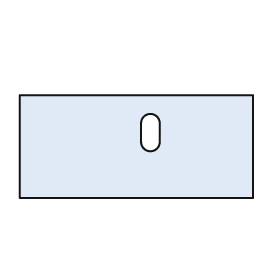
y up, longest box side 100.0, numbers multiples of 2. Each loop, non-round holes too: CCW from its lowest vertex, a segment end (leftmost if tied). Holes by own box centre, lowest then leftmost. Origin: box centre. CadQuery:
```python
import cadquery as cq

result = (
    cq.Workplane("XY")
    .moveTo(-50.0, -22.0)
    .lineTo(50.0, -22.0)
    .lineTo(50.0, 22.0)
    .lineTo(-50.0, 22.0)
    .close()
    .moveTo(2.0, 2.0)
    .threePointArc((6.0, -2.0), (10.0, 2.0))
    .lineTo(10.0, 10.0)
    .threePointArc((6.0, 14.0), (2.0, 10.0))
    .close()
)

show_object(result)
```